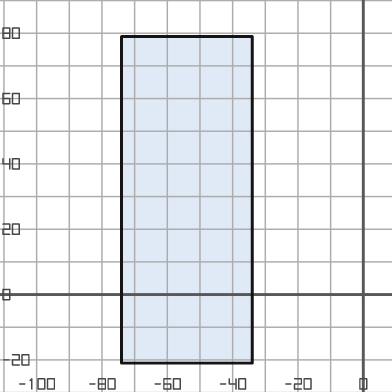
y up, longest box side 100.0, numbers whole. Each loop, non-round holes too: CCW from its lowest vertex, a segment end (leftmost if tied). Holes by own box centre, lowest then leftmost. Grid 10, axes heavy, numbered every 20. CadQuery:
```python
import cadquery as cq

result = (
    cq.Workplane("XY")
    .moveTo(-74.0, -21.0)
    .lineTo(-34.0, -21.0)
    .lineTo(-34.0, 79.0)
    .lineTo(-74.0, 79.0)
    .close()
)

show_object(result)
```